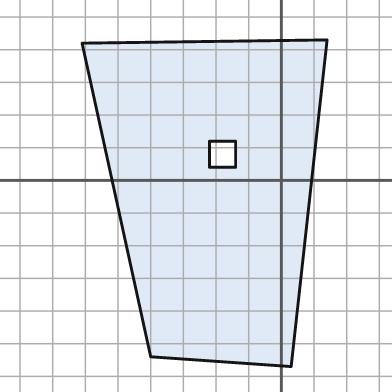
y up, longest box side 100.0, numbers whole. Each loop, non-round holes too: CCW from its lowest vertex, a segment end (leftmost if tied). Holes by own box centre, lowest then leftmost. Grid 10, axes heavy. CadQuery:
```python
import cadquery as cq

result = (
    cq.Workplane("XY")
    .moveTo(3.0, -57.0)
    .lineTo(14.0, 43.0)
    .lineTo(-61.0, 42.0)
    .lineTo(-40.0, -54.0)
    .close()
    .moveTo(-22.0, 4.0)
    .lineTo(-14.0, 4.0)
    .lineTo(-14.0, 12.0)
    .lineTo(-22.0, 12.0)
    .close()
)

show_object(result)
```